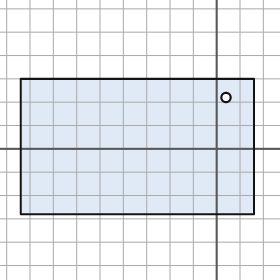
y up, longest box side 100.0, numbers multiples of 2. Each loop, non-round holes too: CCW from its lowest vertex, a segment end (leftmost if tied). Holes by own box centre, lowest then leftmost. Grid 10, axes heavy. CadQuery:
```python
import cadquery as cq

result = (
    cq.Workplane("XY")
    .moveTo(-84.0, -28.0)
    .lineTo(16.0, -28.0)
    .lineTo(16.0, 30.0)
    .lineTo(-84.0, 30.0)
    .close()
    .moveTo(4.0, 22.0)
    .circle(2.0)
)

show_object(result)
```